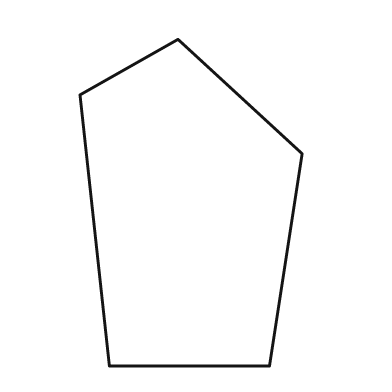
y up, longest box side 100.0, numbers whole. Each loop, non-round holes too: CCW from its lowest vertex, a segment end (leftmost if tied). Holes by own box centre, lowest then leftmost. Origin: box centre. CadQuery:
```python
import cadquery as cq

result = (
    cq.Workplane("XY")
    .moveTo(-25.0, -50.0)
    .lineTo(24.0, -50.0)
    .lineTo(34.0, 15.0)
    .lineTo(-4.0, 50.0)
    .lineTo(-34.0, 33.0)
    .close()
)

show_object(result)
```